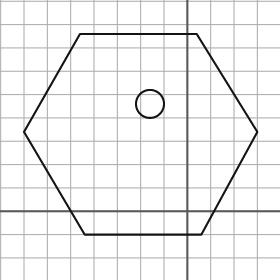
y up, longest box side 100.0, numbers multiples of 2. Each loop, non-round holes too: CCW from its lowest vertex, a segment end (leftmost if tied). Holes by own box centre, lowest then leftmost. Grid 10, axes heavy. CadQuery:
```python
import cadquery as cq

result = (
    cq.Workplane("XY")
    .moveTo(-44.0, -10.0)
    .lineTo(6.0, -10.0)
    .lineTo(30.0, 34.0)
    .lineTo(4.0, 76.0)
    .lineTo(-46.0, 76.0)
    .lineTo(-70.0, 34.0)
    .close()
    .moveTo(-16.0, 46.0)
    .circle(6.0)
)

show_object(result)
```